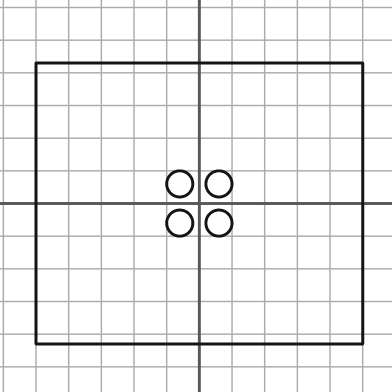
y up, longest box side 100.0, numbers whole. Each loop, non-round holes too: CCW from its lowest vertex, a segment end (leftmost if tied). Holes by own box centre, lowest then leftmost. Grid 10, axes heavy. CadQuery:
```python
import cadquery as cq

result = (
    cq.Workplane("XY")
    .moveTo(-50.0, -43.0)
    .lineTo(50.0, -43.0)
    .lineTo(50.0, 43.0)
    .lineTo(-50.0, 43.0)
    .close()
    .moveTo(-6.0, -6.0)
    .circle(4.0)
    .moveTo(6.0, -6.0)
    .circle(4.0)
    .moveTo(-6.0, 6.0)
    .circle(4.0)
    .moveTo(6.0, 6.0)
    .circle(4.0)
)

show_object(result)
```